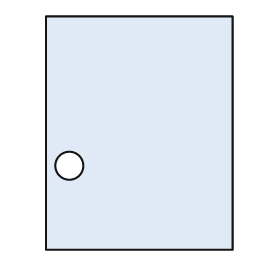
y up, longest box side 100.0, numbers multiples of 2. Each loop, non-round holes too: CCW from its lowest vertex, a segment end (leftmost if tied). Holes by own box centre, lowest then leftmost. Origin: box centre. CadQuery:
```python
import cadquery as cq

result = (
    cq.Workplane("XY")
    .moveTo(-40.0, -50.0)
    .lineTo(40.0, -50.0)
    .lineTo(40.0, 50.0)
    .lineTo(-40.0, 50.0)
    .close()
    .moveTo(-30.0, -14.0)
    .circle(6.0)
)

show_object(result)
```